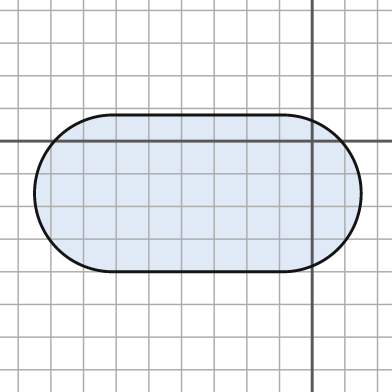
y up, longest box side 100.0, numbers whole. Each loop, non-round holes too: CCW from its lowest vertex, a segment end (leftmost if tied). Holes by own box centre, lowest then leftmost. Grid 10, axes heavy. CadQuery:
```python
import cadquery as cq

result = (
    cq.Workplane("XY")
    .moveTo(-61.0, -40.0)
    .lineTo(-9.0, -40.0)
    .threePointArc((15.0, -16.0), (-9.0, 8.0))
    .lineTo(-61.0, 8.0)
    .threePointArc((-85.0, -16.0), (-61.0, -40.0))
    .close()
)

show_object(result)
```